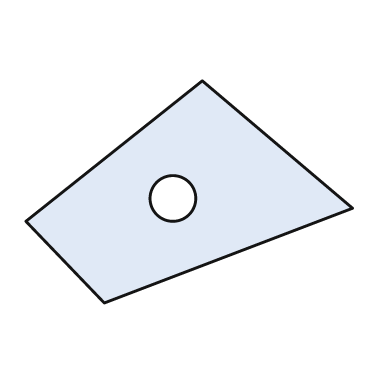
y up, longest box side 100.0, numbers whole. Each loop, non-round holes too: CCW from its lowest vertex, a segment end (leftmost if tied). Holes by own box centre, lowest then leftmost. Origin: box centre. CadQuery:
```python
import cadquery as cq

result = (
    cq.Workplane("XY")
    .moveTo(-26.0, -34.0)
    .lineTo(50.0, -5.0)
    .lineTo(4.0, 34.0)
    .lineTo(-50.0, -9.0)
    .close()
    .moveTo(-5.0, -2.0)
    .circle(7.0)
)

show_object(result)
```